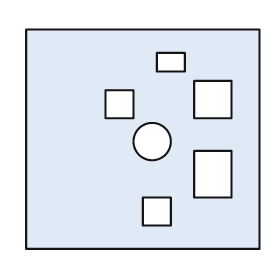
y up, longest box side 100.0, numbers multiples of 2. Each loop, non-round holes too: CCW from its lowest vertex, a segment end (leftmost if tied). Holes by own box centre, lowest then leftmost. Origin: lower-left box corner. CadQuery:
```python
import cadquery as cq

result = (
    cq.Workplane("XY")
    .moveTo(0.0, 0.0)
    .lineTo(100.0, 0.0)
    .lineTo(100.0, 94.0)
    .lineTo(0.0, 94.0)
    .close()
    .moveTo(50.0, 10.0)
    .lineTo(62.0, 10.0)
    .lineTo(62.0, 22.0)
    .lineTo(50.0, 22.0)
    .close()
    .moveTo(72.0, 22.0)
    .lineTo(88.0, 22.0)
    .lineTo(88.0, 42.0)
    .lineTo(72.0, 42.0)
    .close()
    .moveTo(54.0, 46.0)
    .circle(8.0)
    .moveTo(34.0, 56.0)
    .lineTo(46.0, 56.0)
    .lineTo(46.0, 68.0)
    .lineTo(34.0, 68.0)
    .close()
    .moveTo(72.0, 56.0)
    .lineTo(88.0, 56.0)
    .lineTo(88.0, 72.0)
    .lineTo(72.0, 72.0)
    .close()
    .moveTo(56.0, 76.0)
    .lineTo(68.0, 76.0)
    .lineTo(68.0, 84.0)
    .lineTo(56.0, 84.0)
    .close()
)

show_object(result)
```